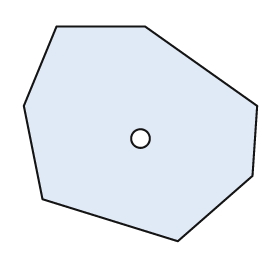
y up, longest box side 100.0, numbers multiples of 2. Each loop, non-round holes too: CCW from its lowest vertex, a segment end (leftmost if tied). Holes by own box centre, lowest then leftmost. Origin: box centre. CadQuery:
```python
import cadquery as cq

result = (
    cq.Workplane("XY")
    .moveTo(16.0, -46.0)
    .lineTo(48.0, -18.0)
    .lineTo(50.0, 12.0)
    .lineTo(2.0, 46.0)
    .lineTo(-36.0, 46.0)
    .lineTo(-50.0, 12.0)
    .lineTo(-42.0, -28.0)
    .close()
    .moveTo(0.0, -2.0)
    .circle(4.0)
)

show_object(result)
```